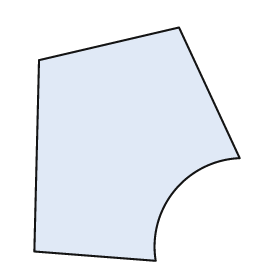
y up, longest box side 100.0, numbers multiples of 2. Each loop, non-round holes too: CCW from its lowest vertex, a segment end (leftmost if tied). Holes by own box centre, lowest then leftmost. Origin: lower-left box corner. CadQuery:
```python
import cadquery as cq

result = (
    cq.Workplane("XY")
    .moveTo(52.0, 0.0)
    .threePointArc((60.0, 30.0), (88.0, 44.0))
    .lineTo(62.0, 100.0)
    .lineTo(2.0, 86.0)
    .lineTo(0.0, 4.0)
    .close()
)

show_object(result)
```